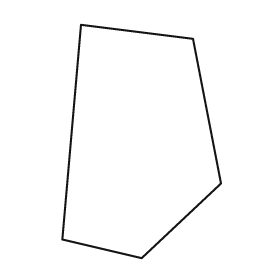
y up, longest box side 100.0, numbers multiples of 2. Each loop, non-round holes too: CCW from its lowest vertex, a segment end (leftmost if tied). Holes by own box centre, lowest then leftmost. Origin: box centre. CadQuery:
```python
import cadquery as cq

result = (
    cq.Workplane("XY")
    .moveTo(0.0, -50.0)
    .lineTo(34.0, -18.0)
    .lineTo(22.0, 44.0)
    .lineTo(-26.0, 50.0)
    .lineTo(-34.0, -42.0)
    .close()
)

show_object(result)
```